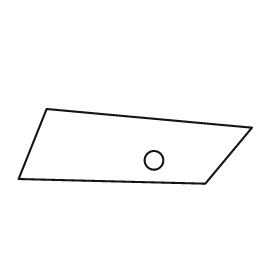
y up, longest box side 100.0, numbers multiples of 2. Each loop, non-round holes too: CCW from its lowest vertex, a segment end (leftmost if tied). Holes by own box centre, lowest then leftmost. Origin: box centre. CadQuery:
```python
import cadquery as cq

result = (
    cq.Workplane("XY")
    .moveTo(30.0, -16.0)
    .lineTo(50.0, 8.0)
    .lineTo(-38.0, 16.0)
    .lineTo(-50.0, -14.0)
    .close()
    .moveTo(8.0, -6.0)
    .circle(4.0)
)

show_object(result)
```